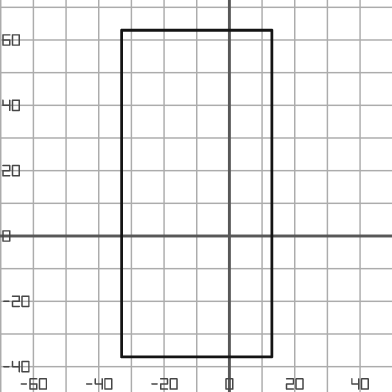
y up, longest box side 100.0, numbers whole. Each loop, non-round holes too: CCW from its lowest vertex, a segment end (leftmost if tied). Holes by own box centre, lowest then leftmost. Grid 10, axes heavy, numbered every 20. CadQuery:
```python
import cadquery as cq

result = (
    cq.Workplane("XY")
    .moveTo(-33.0, -37.0)
    .lineTo(13.0, -37.0)
    .lineTo(13.0, 63.0)
    .lineTo(-33.0, 63.0)
    .close()
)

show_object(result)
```